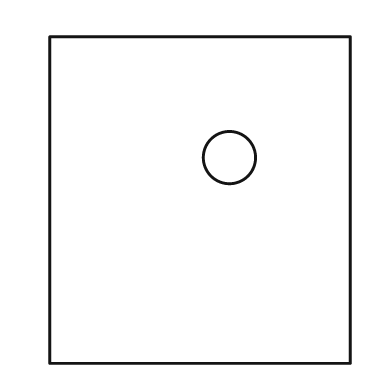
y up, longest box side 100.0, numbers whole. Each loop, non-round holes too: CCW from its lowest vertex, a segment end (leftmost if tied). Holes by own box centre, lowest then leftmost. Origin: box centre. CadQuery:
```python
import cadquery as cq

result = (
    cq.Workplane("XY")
    .moveTo(-46.0, -50.0)
    .lineTo(46.0, -50.0)
    .lineTo(46.0, 50.0)
    .lineTo(-46.0, 50.0)
    .close()
    .moveTo(9.0, 13.0)
    .circle(8.0)
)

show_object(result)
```